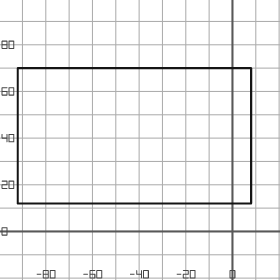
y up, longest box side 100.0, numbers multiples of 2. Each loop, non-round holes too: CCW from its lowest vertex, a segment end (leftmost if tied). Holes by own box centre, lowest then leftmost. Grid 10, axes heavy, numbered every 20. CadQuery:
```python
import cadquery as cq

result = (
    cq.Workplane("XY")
    .moveTo(-92.0, 12.0)
    .lineTo(8.0, 12.0)
    .lineTo(8.0, 70.0)
    .lineTo(-92.0, 70.0)
    .close()
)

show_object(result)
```